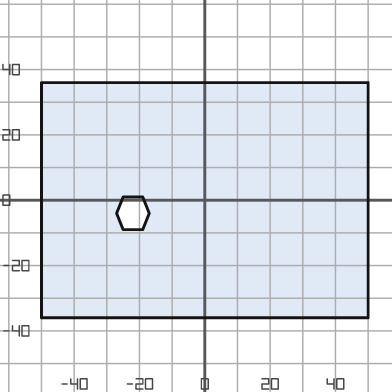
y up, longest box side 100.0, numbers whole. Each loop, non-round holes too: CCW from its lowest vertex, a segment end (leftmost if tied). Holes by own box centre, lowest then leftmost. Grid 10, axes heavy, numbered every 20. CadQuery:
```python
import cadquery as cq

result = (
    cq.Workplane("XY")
    .moveTo(-50.0, -36.0)
    .lineTo(50.0, -36.0)
    .lineTo(50.0, 36.0)
    .lineTo(-50.0, 36.0)
    .close()
    .moveTo(-25.0, -9.0)
    .lineTo(-19.0, -9.0)
    .lineTo(-17.0, -4.0)
    .lineTo(-19.0, 1.0)
    .lineTo(-25.0, 1.0)
    .lineTo(-27.0, -4.0)
    .close()
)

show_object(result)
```